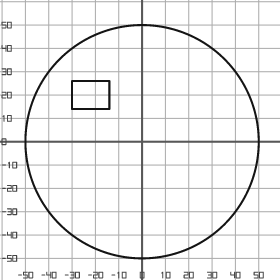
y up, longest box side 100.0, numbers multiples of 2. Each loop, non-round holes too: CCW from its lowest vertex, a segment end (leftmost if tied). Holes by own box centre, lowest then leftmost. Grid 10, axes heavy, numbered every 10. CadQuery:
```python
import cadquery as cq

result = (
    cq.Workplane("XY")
    .moveTo(0.0, 0.0)
    .circle(50.0)
    .moveTo(-30.0, 14.0)
    .lineTo(-14.0, 14.0)
    .lineTo(-14.0, 26.0)
    .lineTo(-30.0, 26.0)
    .close()
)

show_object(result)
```